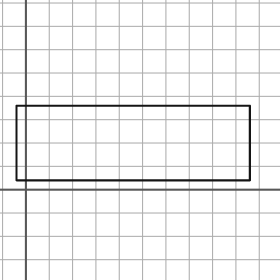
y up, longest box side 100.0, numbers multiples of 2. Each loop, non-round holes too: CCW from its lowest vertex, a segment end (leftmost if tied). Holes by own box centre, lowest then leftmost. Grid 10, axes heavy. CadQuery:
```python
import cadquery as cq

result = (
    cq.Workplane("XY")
    .moveTo(-4.0, 4.0)
    .lineTo(96.0, 4.0)
    .lineTo(96.0, 36.0)
    .lineTo(-4.0, 36.0)
    .close()
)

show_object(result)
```